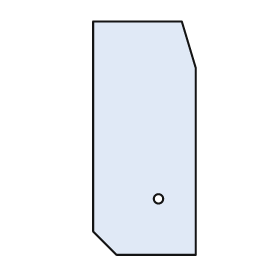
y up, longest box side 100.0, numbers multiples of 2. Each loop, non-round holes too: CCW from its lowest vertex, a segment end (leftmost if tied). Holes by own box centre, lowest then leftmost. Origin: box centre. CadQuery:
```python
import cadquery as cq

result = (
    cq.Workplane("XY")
    .moveTo(-12.0, -50.0)
    .lineTo(22.0, -50.0)
    .lineTo(22.0, 30.0)
    .lineTo(16.0, 50.0)
    .lineTo(-22.0, 50.0)
    .lineTo(-22.0, -40.0)
    .close()
    .moveTo(6.0, -26.0)
    .circle(2.0)
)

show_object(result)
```